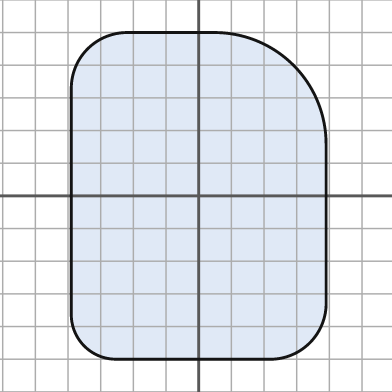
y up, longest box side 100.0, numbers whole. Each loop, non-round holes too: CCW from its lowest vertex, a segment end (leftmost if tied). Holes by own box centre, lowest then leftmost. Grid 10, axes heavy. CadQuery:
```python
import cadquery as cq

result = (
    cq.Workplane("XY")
    .moveTo(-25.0, -50.0)
    .lineTo(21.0, -50.0)
    .threePointArc((34.0, -45.0), (39.0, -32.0))
    .lineTo(39.0, 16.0)
    .threePointArc((29.0, 40.0), (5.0, 50.0))
    .lineTo(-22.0, 50.0)
    .threePointArc((-34.0, 45.0), (-39.0, 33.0))
    .lineTo(-39.0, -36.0)
    .threePointArc((-35.0, -46.0), (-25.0, -50.0))
    .close()
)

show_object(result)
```